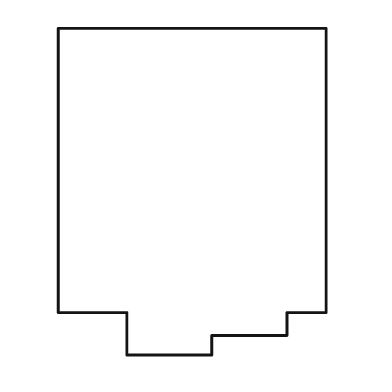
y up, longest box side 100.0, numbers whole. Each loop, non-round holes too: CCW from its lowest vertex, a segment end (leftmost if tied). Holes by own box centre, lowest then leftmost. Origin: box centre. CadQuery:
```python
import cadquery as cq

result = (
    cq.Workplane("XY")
    .moveTo(-20.0, -50.0)
    .lineTo(6.0, -50.0)
    .lineTo(6.0, -44.0)
    .lineTo(29.0, -44.0)
    .lineTo(29.0, -37.0)
    .lineTo(41.0, -37.0)
    .lineTo(41.0, 50.0)
    .lineTo(-41.0, 50.0)
    .lineTo(-41.0, -37.0)
    .lineTo(-20.0, -37.0)
    .close()
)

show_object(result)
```